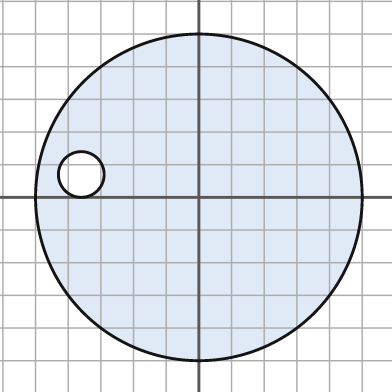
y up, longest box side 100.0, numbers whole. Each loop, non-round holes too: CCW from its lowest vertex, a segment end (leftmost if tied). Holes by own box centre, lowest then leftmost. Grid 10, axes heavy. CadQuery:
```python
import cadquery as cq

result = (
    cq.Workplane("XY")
    .moveTo(0.0, 0.0)
    .circle(50.0)
    .moveTo(-36.0, 7.0)
    .circle(7.0)
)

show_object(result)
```